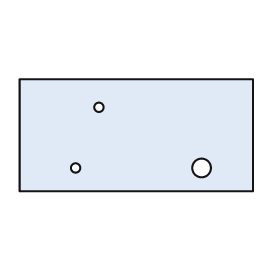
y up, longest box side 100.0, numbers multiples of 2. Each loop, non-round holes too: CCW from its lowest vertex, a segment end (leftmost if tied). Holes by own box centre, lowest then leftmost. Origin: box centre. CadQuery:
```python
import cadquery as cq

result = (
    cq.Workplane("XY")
    .moveTo(-50.0, -24.0)
    .lineTo(50.0, -24.0)
    .lineTo(50.0, 24.0)
    .lineTo(-50.0, 24.0)
    .close()
    .moveTo(-26.0, -14.0)
    .circle(2.0)
    .moveTo(28.0, -14.0)
    .circle(4.0)
    .moveTo(-16.0, 12.0)
    .circle(2.0)
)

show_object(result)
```